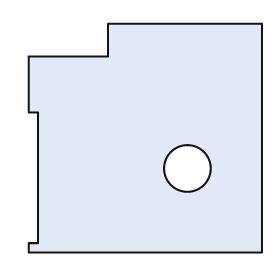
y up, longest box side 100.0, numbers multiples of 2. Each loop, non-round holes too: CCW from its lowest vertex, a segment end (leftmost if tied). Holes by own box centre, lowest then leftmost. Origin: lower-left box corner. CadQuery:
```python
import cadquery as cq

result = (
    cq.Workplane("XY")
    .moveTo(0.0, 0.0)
    .lineTo(100.0, 0.0)
    .lineTo(100.0, 98.0)
    .lineTo(34.0, 98.0)
    .lineTo(34.0, 84.0)
    .lineTo(0.0, 84.0)
    .lineTo(0.0, 60.0)
    .lineTo(4.0, 60.0)
    .lineTo(4.0, 4.0)
    .lineTo(0.0, 4.0)
    .close()
    .moveTo(68.0, 36.0)
    .circle(10.0)
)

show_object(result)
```